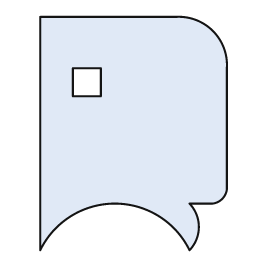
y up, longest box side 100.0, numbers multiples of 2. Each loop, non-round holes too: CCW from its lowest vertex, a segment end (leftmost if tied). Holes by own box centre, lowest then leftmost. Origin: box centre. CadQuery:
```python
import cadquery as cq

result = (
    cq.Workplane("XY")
    .moveTo(-40.0, -50.0)
    .threePointArc((-8.0, -30.0), (24.0, -50.0))
    .threePointArc((28.0, -40.0), (24.0, -30.0))
    .lineTo(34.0, -30.0)
    .threePointArc((38.0, -28.0), (40.0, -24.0))
    .lineTo(40.0, 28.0)
    .threePointArc((34.0, 44.0), (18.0, 50.0))
    .lineTo(-40.0, 50.0)
    .close()
    .moveTo(-26.0, 16.0)
    .lineTo(-14.0, 16.0)
    .lineTo(-14.0, 28.0)
    .lineTo(-26.0, 28.0)
    .close()
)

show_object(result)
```